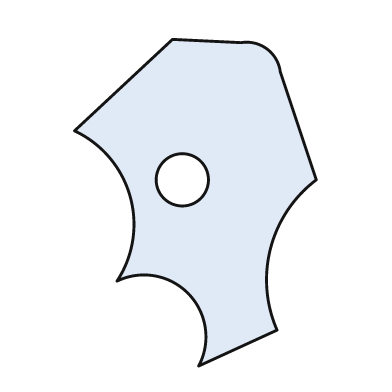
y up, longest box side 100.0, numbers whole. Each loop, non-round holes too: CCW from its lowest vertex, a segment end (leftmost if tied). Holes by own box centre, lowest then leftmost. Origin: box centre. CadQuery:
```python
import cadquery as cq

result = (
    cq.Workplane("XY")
    .moveTo(1.0, -50.0)
    .lineTo(25.0, -39.0)
    .threePointArc((23.0, -14.0), (37.0, 7.0))
    .lineTo(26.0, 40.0)
    .threePointArc((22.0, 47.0), (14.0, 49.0))
    .lineTo(-7.0, 50.0)
    .lineTo(-37.0, 22.0)
    .threePointArc((-20.0, 2.0), (-24.0, -24.0))
    .threePointArc((-2.0, -28.0), (1.0, -50.0))
    .close()
    .moveTo(-4.0, 7.0)
    .circle(8.0)
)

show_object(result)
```